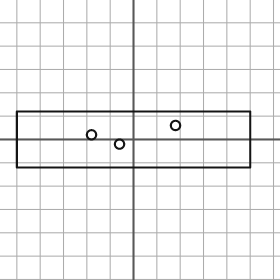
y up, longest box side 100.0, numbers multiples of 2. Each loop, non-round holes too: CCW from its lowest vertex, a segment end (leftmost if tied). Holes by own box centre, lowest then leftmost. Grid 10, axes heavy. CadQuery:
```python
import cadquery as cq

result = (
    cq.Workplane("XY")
    .moveTo(-50.0, -12.0)
    .lineTo(50.0, -12.0)
    .lineTo(50.0, 12.0)
    .lineTo(-50.0, 12.0)
    .close()
    .moveTo(-6.0, -2.0)
    .circle(2.0)
    .moveTo(-18.0, 2.0)
    .circle(2.0)
    .moveTo(18.0, 6.0)
    .circle(2.0)
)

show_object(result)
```